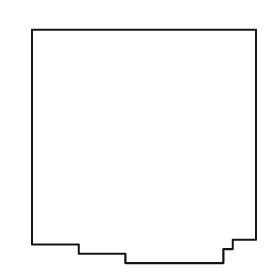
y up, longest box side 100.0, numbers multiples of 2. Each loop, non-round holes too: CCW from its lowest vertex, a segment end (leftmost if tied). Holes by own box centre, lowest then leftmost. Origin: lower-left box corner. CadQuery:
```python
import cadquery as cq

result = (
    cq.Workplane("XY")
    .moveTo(40.0, 0.0)
    .lineTo(82.0, 0.0)
    .lineTo(82.0, 6.0)
    .lineTo(86.0, 6.0)
    .lineTo(86.0, 10.0)
    .lineTo(96.0, 10.0)
    .lineTo(96.0, 100.0)
    .lineTo(0.0, 100.0)
    .lineTo(0.0, 8.0)
    .lineTo(20.0, 8.0)
    .lineTo(20.0, 4.0)
    .lineTo(40.0, 4.0)
    .close()
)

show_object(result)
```